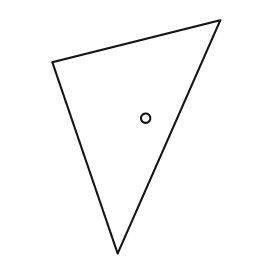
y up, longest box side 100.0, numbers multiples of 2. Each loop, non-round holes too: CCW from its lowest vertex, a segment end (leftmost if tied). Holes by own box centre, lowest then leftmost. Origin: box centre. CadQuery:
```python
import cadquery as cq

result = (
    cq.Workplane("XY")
    .moveTo(-8.0, -50.0)
    .lineTo(36.0, 50.0)
    .lineTo(-36.0, 32.0)
    .close()
    .moveTo(4.0, 8.0)
    .circle(2.0)
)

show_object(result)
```